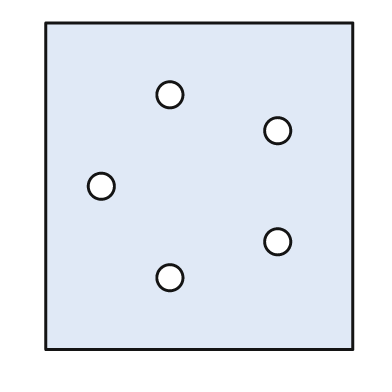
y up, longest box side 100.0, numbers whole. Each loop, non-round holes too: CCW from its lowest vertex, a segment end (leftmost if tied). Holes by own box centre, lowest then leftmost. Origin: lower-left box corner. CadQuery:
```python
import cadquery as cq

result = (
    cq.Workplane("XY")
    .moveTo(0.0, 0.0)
    .lineTo(94.0, 0.0)
    .lineTo(94.0, 100.0)
    .lineTo(0.0, 100.0)
    .close()
    .moveTo(38.0, 22.0)
    .circle(4.0)
    .moveTo(71.0, 33.0)
    .circle(4.0)
    .moveTo(17.0, 50.0)
    .circle(4.0)
    .moveTo(71.0, 67.0)
    .circle(4.0)
    .moveTo(38.0, 78.0)
    .circle(4.0)
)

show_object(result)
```